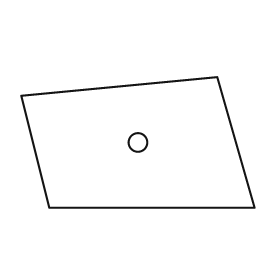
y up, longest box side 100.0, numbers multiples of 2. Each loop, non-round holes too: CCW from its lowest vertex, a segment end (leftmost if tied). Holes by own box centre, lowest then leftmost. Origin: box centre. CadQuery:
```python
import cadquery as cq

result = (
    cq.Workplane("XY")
    .moveTo(-38.0, -28.0)
    .lineTo(50.0, -28.0)
    .lineTo(34.0, 28.0)
    .lineTo(-50.0, 20.0)
    .close()
    .moveTo(0.0, 0.0)
    .circle(4.0)
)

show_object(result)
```